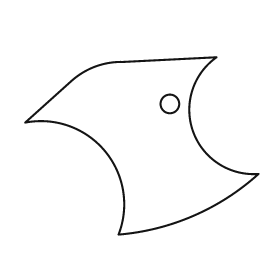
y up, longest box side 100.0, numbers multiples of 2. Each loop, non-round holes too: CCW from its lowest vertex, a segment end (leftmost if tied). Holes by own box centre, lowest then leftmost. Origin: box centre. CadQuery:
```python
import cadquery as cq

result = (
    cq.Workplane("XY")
    .moveTo(-10.0, -38.0)
    .threePointArc((22.0, -30.0), (50.0, -12.0))
    .threePointArc((22.0, 6.0), (32.0, 38.0))
    .lineTo(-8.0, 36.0)
    .threePointArc((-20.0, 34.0), (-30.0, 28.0))
    .lineTo(-50.0, 10.0)
    .threePointArc((-16.0, -2.0), (-10.0, -38.0))
    .close()
    .moveTo(12.0, 18.0)
    .circle(4.0)
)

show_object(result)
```